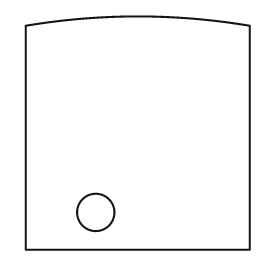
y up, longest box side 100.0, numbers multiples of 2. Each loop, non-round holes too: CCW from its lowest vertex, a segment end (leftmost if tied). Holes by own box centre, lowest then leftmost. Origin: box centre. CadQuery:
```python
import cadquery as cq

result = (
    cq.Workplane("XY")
    .moveTo(-48.0, -50.0)
    .lineTo(48.0, -50.0)
    .lineTo(48.0, 46.0)
    .threePointArc((0.0, 50.0), (-48.0, 46.0))
    .close()
    .moveTo(-18.0, -34.0)
    .circle(8.0)
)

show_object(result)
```